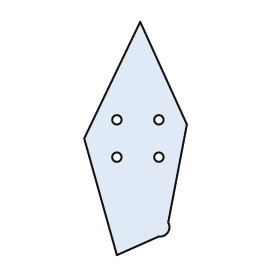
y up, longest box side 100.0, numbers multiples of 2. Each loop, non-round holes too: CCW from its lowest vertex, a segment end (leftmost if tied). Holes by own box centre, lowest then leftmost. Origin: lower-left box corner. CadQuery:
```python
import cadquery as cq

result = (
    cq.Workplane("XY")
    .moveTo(14.0, 0.0)
    .lineTo(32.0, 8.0)
    .threePointArc((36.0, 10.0), (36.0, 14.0))
    .lineTo(44.0, 56.0)
    .lineTo(24.0, 100.0)
    .lineTo(0.0, 50.0)
    .close()
    .moveTo(14.0, 42.0)
    .circle(2.0)
    .moveTo(32.0, 42.0)
    .circle(2.0)
    .moveTo(14.0, 58.0)
    .circle(2.0)
    .moveTo(32.0, 58.0)
    .circle(2.0)
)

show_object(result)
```